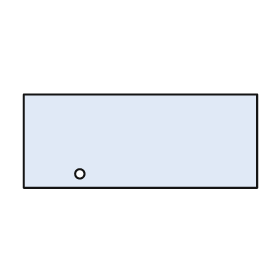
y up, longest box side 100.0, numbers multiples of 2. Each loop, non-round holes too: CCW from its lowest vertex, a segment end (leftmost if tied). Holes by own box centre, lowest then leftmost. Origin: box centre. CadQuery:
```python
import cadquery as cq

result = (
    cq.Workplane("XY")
    .moveTo(-50.0, -20.0)
    .lineTo(50.0, -20.0)
    .lineTo(50.0, 20.0)
    .lineTo(-50.0, 20.0)
    .close()
    .moveTo(-26.0, -14.0)
    .circle(2.0)
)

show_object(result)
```